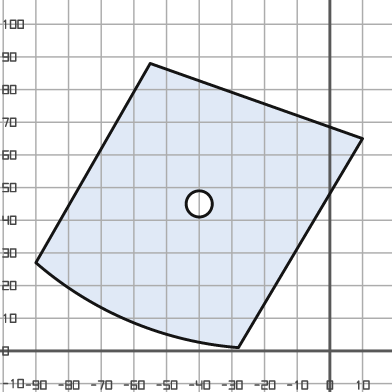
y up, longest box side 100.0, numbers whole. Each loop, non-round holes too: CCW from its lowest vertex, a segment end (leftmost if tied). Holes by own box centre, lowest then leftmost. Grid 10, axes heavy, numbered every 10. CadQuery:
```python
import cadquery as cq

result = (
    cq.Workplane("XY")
    .moveTo(-28.0, 1.0)
    .lineTo(10.0, 65.0)
    .lineTo(-55.0, 88.0)
    .lineTo(-90.0, 27.0)
    .threePointArc((-61.0, 9.0), (-28.0, 1.0))
    .close()
    .moveTo(-40.0, 45.0)
    .circle(4.0)
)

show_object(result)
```